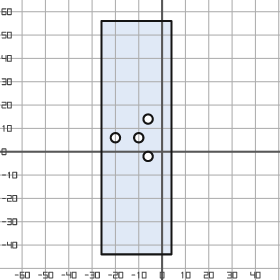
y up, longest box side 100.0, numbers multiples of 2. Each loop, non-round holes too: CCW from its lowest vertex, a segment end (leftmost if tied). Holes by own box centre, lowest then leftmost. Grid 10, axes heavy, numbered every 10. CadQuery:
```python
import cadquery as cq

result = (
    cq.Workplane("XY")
    .moveTo(-26.0, -44.0)
    .lineTo(4.0, -44.0)
    .lineTo(4.0, 56.0)
    .lineTo(-26.0, 56.0)
    .close()
    .moveTo(-6.0, -2.0)
    .circle(2.0)
    .moveTo(-20.0, 6.0)
    .circle(2.0)
    .moveTo(-10.0, 6.0)
    .circle(2.0)
    .moveTo(-6.0, 14.0)
    .circle(2.0)
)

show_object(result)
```